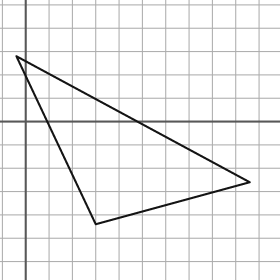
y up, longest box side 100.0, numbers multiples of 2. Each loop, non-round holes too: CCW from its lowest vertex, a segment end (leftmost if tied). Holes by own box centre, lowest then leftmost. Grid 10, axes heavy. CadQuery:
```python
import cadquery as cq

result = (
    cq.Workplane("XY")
    .moveTo(30.0, -44.0)
    .lineTo(96.0, -26.0)
    .lineTo(-4.0, 28.0)
    .close()
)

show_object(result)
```